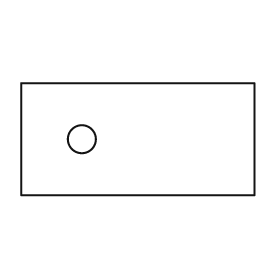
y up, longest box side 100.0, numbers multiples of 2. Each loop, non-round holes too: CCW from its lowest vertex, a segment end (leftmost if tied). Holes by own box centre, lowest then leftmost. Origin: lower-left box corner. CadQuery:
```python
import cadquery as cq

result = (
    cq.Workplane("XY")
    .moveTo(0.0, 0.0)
    .lineTo(100.0, 0.0)
    .lineTo(100.0, 48.0)
    .lineTo(0.0, 48.0)
    .close()
    .moveTo(26.0, 24.0)
    .circle(6.0)
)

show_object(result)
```